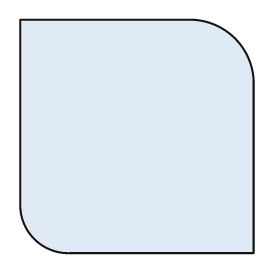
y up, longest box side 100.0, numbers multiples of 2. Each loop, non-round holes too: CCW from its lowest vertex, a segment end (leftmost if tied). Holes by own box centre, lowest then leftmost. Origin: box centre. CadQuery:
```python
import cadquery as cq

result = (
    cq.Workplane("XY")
    .moveTo(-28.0, -50.0)
    .lineTo(50.0, -50.0)
    .lineTo(50.0, 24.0)
    .threePointArc((42.0, 42.0), (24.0, 50.0))
    .lineTo(-50.0, 50.0)
    .lineTo(-50.0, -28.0)
    .threePointArc((-44.0, -44.0), (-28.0, -50.0))
    .close()
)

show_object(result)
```